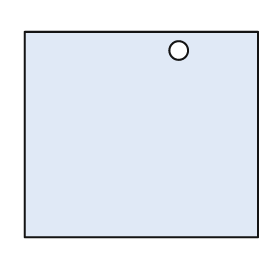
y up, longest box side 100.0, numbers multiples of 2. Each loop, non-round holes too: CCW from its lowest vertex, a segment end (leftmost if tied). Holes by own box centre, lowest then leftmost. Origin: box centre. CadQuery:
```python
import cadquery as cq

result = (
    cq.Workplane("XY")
    .moveTo(-50.0, -44.0)
    .lineTo(50.0, -44.0)
    .lineTo(50.0, 44.0)
    .lineTo(-50.0, 44.0)
    .close()
    .moveTo(16.0, 36.0)
    .circle(4.0)
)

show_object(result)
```